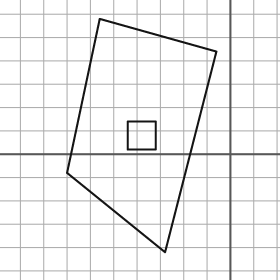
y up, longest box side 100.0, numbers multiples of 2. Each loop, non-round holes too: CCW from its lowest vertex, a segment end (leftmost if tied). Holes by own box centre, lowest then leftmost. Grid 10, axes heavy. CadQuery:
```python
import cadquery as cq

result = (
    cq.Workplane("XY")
    .moveTo(-28.0, -42.0)
    .lineTo(-6.0, 44.0)
    .lineTo(-56.0, 58.0)
    .lineTo(-70.0, -8.0)
    .close()
    .moveTo(-44.0, 2.0)
    .lineTo(-32.0, 2.0)
    .lineTo(-32.0, 14.0)
    .lineTo(-44.0, 14.0)
    .close()
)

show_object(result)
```